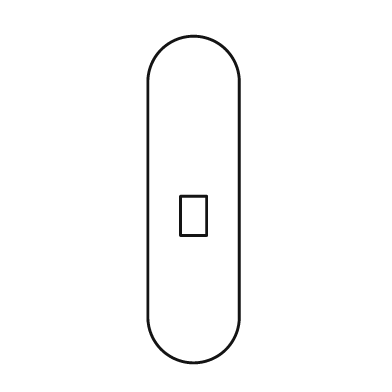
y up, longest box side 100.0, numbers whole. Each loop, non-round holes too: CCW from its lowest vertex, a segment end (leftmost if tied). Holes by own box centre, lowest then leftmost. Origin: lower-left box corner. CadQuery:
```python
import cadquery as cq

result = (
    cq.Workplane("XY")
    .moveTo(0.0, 14.0)
    .threePointArc((14.0, 0.0), (28.0, 14.0))
    .lineTo(28.0, 86.0)
    .threePointArc((14.0, 100.0), (0.0, 86.0))
    .close()
    .moveTo(10.0, 39.0)
    .lineTo(18.0, 39.0)
    .lineTo(18.0, 51.0)
    .lineTo(10.0, 51.0)
    .close()
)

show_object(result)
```